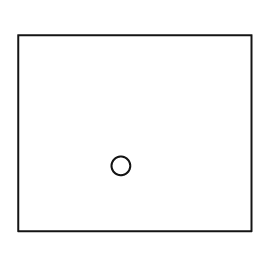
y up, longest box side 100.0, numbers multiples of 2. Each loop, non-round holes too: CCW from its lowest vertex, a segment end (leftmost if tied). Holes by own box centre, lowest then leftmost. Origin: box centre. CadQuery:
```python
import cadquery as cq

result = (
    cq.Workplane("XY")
    .moveTo(-50.0, -42.0)
    .lineTo(50.0, -42.0)
    .lineTo(50.0, 42.0)
    .lineTo(-50.0, 42.0)
    .close()
    .moveTo(-6.0, -14.0)
    .circle(4.0)
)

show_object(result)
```